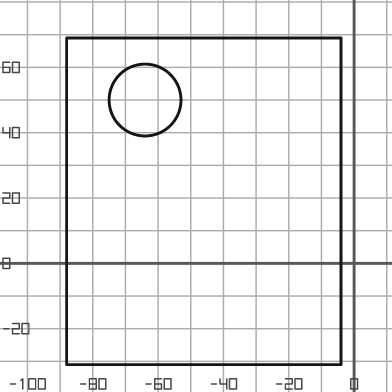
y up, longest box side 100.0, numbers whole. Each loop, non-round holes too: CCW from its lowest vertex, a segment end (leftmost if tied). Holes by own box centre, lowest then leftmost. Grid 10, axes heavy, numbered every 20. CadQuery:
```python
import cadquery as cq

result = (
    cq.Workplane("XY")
    .moveTo(-88.0, -31.0)
    .lineTo(-4.0, -31.0)
    .lineTo(-4.0, 69.0)
    .lineTo(-88.0, 69.0)
    .close()
    .moveTo(-64.0, 50.0)
    .circle(11.0)
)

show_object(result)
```